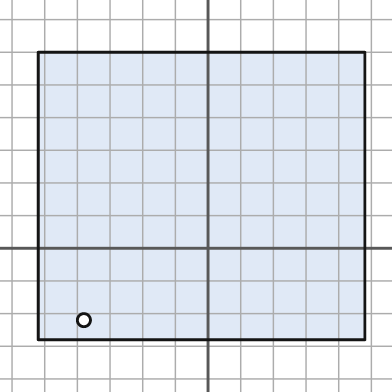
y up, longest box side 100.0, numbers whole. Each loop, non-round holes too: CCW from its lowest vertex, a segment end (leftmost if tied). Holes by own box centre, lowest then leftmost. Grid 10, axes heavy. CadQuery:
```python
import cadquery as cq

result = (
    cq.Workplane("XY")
    .moveTo(-52.0, -28.0)
    .lineTo(48.0, -28.0)
    .lineTo(48.0, 60.0)
    .lineTo(-52.0, 60.0)
    .close()
    .moveTo(-38.0, -22.0)
    .circle(2.0)
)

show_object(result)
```